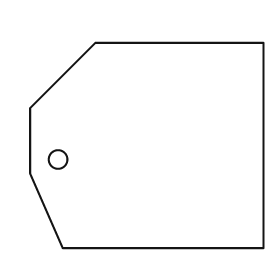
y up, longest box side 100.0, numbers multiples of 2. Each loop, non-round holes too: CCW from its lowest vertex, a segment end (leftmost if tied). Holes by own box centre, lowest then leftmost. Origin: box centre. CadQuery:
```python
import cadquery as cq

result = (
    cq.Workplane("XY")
    .moveTo(-36.0, -44.0)
    .lineTo(50.0, -44.0)
    .lineTo(50.0, 44.0)
    .lineTo(-22.0, 44.0)
    .lineTo(-50.0, 16.0)
    .lineTo(-50.0, -12.0)
    .close()
    .moveTo(-38.0, -6.0)
    .circle(4.0)
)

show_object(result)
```